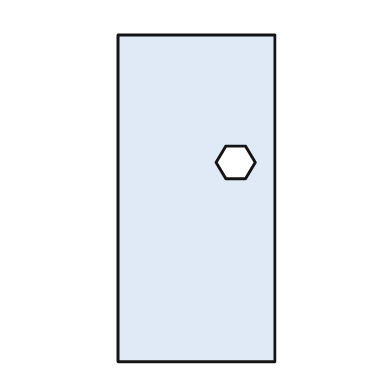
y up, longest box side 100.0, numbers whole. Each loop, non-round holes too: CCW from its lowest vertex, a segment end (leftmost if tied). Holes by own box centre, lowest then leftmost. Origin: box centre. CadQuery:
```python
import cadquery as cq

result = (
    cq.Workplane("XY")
    .moveTo(-24.0, -50.0)
    .lineTo(24.0, -50.0)
    .lineTo(24.0, 50.0)
    .lineTo(-24.0, 50.0)
    .close()
    .moveTo(9.0, 6.0)
    .lineTo(15.0, 6.0)
    .lineTo(18.0, 11.0)
    .lineTo(15.0, 16.0)
    .lineTo(9.0, 16.0)
    .lineTo(6.0, 11.0)
    .close()
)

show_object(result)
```